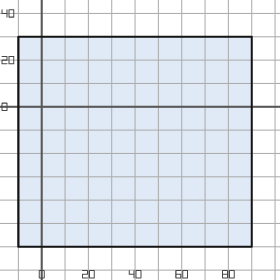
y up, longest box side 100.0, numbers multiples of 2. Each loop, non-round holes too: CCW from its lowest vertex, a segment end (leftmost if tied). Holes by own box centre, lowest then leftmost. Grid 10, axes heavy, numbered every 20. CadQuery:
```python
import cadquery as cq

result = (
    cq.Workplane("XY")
    .moveTo(-10.0, -60.0)
    .lineTo(90.0, -60.0)
    .lineTo(90.0, 30.0)
    .lineTo(-10.0, 30.0)
    .close()
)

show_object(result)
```